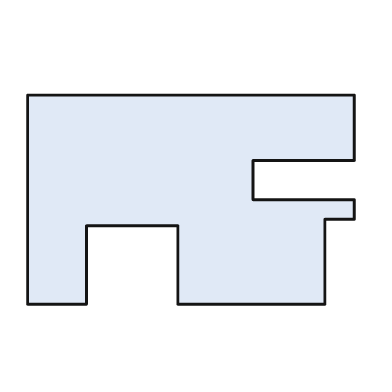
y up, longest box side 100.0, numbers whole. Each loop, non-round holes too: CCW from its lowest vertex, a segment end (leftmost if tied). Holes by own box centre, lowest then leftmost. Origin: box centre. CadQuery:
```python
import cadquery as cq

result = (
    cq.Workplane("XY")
    .moveTo(-50.0, -32.0)
    .lineTo(-32.0, -32.0)
    .lineTo(-32.0, -8.0)
    .lineTo(-4.0, -8.0)
    .lineTo(-4.0, -32.0)
    .lineTo(41.0, -32.0)
    .lineTo(41.0, -6.0)
    .lineTo(50.0, -6.0)
    .lineTo(50.0, 0.0)
    .lineTo(19.0, 0.0)
    .lineTo(19.0, 12.0)
    .lineTo(50.0, 12.0)
    .lineTo(50.0, 32.0)
    .lineTo(-50.0, 32.0)
    .close()
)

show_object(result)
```